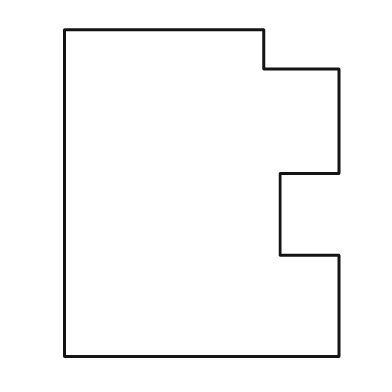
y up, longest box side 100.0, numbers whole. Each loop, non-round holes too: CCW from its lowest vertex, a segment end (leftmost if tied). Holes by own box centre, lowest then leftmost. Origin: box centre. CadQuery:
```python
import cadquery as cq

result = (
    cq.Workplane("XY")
    .moveTo(-42.0, -50.0)
    .lineTo(42.0, -50.0)
    .lineTo(42.0, -19.0)
    .lineTo(24.0, -19.0)
    .lineTo(24.0, 6.0)
    .lineTo(42.0, 6.0)
    .lineTo(42.0, 38.0)
    .lineTo(19.0, 38.0)
    .lineTo(19.0, 50.0)
    .lineTo(-42.0, 50.0)
    .close()
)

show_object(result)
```